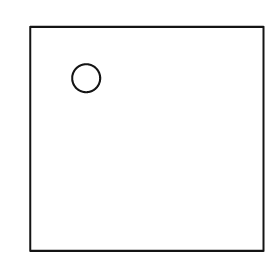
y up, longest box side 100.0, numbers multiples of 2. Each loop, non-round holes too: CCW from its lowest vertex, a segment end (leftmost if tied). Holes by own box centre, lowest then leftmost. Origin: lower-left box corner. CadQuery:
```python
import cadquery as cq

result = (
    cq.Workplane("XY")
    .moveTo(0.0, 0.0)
    .lineTo(100.0, 0.0)
    .lineTo(100.0, 96.0)
    .lineTo(0.0, 96.0)
    .close()
    .moveTo(24.0, 74.0)
    .circle(6.0)
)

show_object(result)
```